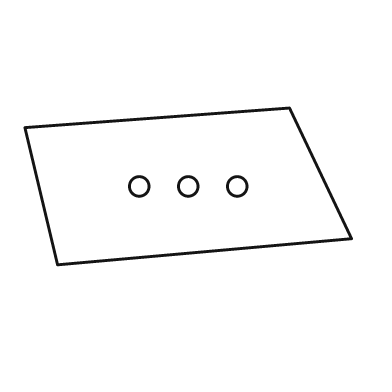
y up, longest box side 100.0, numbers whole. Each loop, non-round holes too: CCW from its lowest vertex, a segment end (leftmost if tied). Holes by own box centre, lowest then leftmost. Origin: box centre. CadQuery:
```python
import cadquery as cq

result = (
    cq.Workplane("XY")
    .moveTo(-40.0, -24.0)
    .lineTo(50.0, -16.0)
    .lineTo(31.0, 24.0)
    .lineTo(-50.0, 18.0)
    .close()
    .moveTo(-15.0, 0.0)
    .circle(3.0)
    .moveTo(0.0, 0.0)
    .circle(3.0)
    .moveTo(15.0, 0.0)
    .circle(3.0)
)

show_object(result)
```